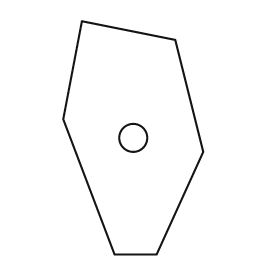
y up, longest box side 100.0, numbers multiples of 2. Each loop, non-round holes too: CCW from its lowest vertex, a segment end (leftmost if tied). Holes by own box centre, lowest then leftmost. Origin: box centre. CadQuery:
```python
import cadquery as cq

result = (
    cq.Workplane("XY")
    .moveTo(-8.0, -50.0)
    .lineTo(10.0, -50.0)
    .lineTo(30.0, -6.0)
    .lineTo(18.0, 42.0)
    .lineTo(-22.0, 50.0)
    .lineTo(-30.0, 8.0)
    .close()
    .moveTo(0.0, 0.0)
    .circle(6.0)
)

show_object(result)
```